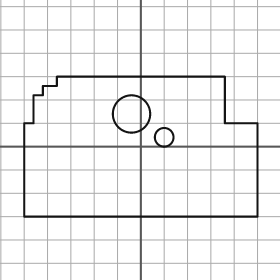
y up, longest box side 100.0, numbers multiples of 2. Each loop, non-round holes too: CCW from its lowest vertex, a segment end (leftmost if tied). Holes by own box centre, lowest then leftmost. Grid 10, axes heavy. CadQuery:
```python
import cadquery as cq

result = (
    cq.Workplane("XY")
    .moveTo(-50.0, -30.0)
    .lineTo(50.0, -30.0)
    .lineTo(50.0, 10.0)
    .lineTo(36.0, 10.0)
    .lineTo(36.0, 30.0)
    .lineTo(-36.0, 30.0)
    .lineTo(-36.0, 26.0)
    .lineTo(-42.0, 26.0)
    .lineTo(-42.0, 22.0)
    .lineTo(-46.0, 22.0)
    .lineTo(-46.0, 10.0)
    .lineTo(-50.0, 10.0)
    .close()
    .moveTo(10.0, 4.0)
    .circle(4.0)
    .moveTo(-4.0, 14.0)
    .circle(8.0)
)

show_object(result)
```